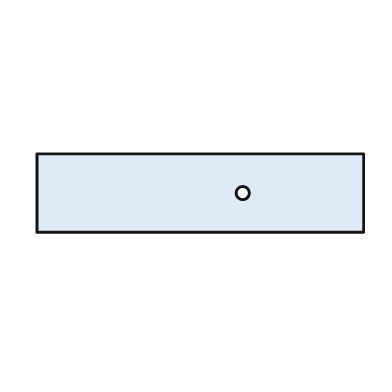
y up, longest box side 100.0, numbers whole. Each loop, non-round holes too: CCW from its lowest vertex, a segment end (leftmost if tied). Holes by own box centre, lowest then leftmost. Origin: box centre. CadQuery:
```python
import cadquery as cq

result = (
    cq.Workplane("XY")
    .moveTo(-50.0, -12.0)
    .lineTo(50.0, -12.0)
    .lineTo(50.0, 12.0)
    .lineTo(-50.0, 12.0)
    .close()
    .moveTo(13.0, 0.0)
    .circle(2.0)
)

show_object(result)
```